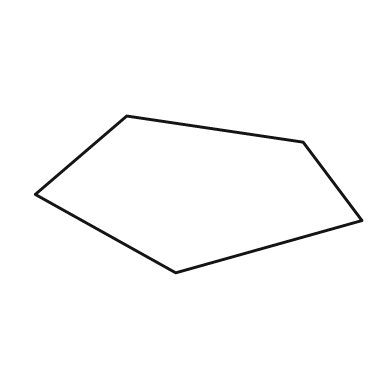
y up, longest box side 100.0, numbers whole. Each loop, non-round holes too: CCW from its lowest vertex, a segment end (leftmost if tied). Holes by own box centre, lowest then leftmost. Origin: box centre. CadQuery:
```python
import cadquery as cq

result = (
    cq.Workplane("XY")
    .moveTo(-7.0, -24.0)
    .lineTo(50.0, -8.0)
    .lineTo(32.0, 16.0)
    .lineTo(-22.0, 24.0)
    .lineTo(-50.0, 0.0)
    .close()
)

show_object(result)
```